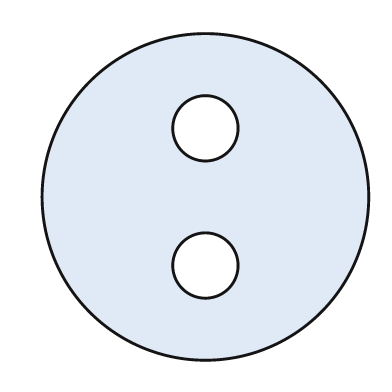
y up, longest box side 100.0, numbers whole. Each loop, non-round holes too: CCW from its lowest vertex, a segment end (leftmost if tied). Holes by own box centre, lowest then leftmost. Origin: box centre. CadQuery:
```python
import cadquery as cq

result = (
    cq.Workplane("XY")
    .moveTo(0.0, 0.0)
    .circle(50.0)
    .moveTo(0.0, -21.0)
    .circle(10.0)
    .moveTo(0.0, 21.0)
    .circle(10.0)
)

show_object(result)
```